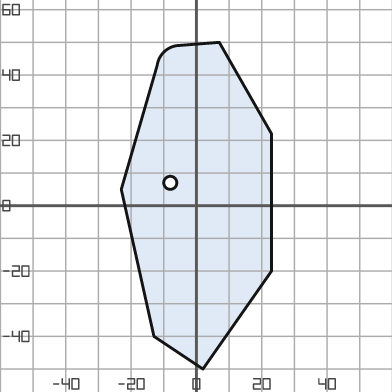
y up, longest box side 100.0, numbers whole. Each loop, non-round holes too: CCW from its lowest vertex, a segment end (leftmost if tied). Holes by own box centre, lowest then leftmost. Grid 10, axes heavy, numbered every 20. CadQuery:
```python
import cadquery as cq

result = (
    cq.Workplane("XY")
    .moveTo(2.0, -50.0)
    .lineTo(23.0, -20.0)
    .lineTo(23.0, 22.0)
    .lineTo(7.0, 50.0)
    .lineTo(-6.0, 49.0)
    .threePointArc((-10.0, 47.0), (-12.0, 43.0))
    .lineTo(-23.0, 5.0)
    .lineTo(-13.0, -40.0)
    .close()
    .moveTo(-8.0, 7.0)
    .circle(2.0)
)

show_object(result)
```